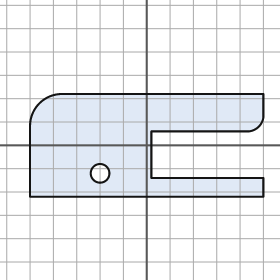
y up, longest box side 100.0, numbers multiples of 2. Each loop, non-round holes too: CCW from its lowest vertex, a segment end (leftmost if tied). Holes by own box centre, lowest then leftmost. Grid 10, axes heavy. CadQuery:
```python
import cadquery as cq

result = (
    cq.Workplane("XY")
    .moveTo(-50.0, -22.0)
    .lineTo(50.0, -22.0)
    .lineTo(50.0, -14.0)
    .lineTo(2.0, -14.0)
    .lineTo(2.0, 6.0)
    .lineTo(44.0, 6.0)
    .threePointArc((48.0, 8.0), (50.0, 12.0))
    .lineTo(50.0, 22.0)
    .lineTo(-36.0, 22.0)
    .threePointArc((-46.0, 18.0), (-50.0, 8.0))
    .close()
    .moveTo(-20.0, -12.0)
    .circle(4.0)
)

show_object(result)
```